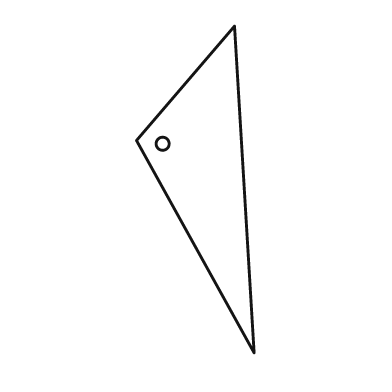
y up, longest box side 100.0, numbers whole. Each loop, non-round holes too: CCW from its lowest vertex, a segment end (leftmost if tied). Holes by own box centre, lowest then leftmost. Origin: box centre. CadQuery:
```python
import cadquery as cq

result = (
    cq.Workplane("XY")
    .moveTo(18.0, -50.0)
    .lineTo(12.0, 50.0)
    .lineTo(-18.0, 15.0)
    .close()
    .moveTo(-10.0, 14.0)
    .circle(2.0)
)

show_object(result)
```